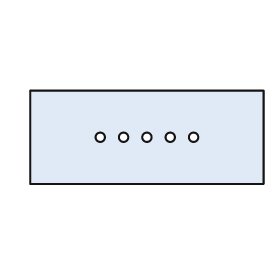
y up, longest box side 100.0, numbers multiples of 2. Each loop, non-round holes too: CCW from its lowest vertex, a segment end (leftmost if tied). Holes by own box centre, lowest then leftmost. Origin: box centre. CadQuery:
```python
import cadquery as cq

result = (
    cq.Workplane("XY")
    .moveTo(-50.0, -20.0)
    .lineTo(50.0, -20.0)
    .lineTo(50.0, 20.0)
    .lineTo(-50.0, 20.0)
    .close()
    .moveTo(-20.0, 0.0)
    .circle(2.0)
    .moveTo(-10.0, 0.0)
    .circle(2.0)
    .moveTo(0.0, 0.0)
    .circle(2.0)
    .moveTo(10.0, 0.0)
    .circle(2.0)
    .moveTo(20.0, 0.0)
    .circle(2.0)
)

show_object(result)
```